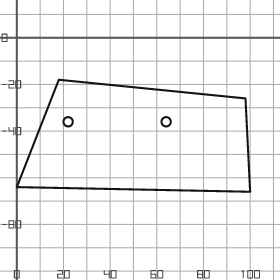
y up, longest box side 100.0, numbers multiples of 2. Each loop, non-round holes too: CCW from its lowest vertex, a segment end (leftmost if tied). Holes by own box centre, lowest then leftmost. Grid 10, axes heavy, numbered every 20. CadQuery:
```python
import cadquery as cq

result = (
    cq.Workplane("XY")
    .moveTo(100.0, -66.0)
    .lineTo(98.0, -26.0)
    .lineTo(18.0, -18.0)
    .lineTo(0.0, -64.0)
    .close()
    .moveTo(22.0, -36.0)
    .circle(2.0)
    .moveTo(64.0, -36.0)
    .circle(2.0)
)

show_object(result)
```